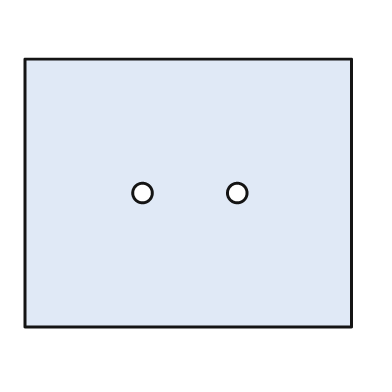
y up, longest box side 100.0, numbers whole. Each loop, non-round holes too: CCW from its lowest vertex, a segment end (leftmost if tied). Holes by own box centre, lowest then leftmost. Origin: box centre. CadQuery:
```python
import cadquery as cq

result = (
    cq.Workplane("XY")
    .moveTo(-50.0, -41.0)
    .lineTo(50.0, -41.0)
    .lineTo(50.0, 41.0)
    .lineTo(-50.0, 41.0)
    .close()
    .moveTo(-14.0, 0.0)
    .circle(3.0)
    .moveTo(15.0, 0.0)
    .circle(3.0)
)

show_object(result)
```